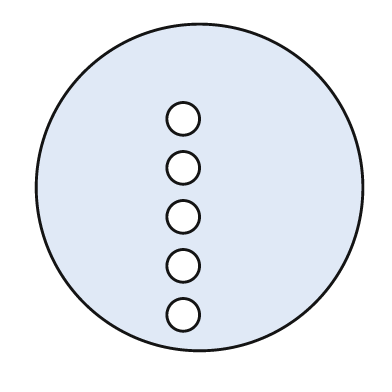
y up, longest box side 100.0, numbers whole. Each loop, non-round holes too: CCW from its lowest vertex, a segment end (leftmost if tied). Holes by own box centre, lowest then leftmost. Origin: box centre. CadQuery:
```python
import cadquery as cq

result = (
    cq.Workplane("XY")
    .moveTo(0.0, 0.0)
    .circle(50.0)
    .moveTo(-5.0, -39.0)
    .circle(5.0)
    .moveTo(-5.0, -24.0)
    .circle(5.0)
    .moveTo(-5.0, -9.0)
    .circle(5.0)
    .moveTo(-5.0, 6.0)
    .circle(5.0)
    .moveTo(-5.0, 21.0)
    .circle(5.0)
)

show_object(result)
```